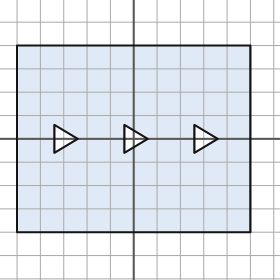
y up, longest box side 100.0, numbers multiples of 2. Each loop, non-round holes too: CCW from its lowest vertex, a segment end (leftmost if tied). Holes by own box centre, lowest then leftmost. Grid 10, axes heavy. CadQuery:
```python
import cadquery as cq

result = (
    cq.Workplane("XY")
    .moveTo(-50.0, -40.0)
    .lineTo(50.0, -40.0)
    .lineTo(50.0, 40.0)
    .lineTo(-50.0, 40.0)
    .close()
    .moveTo(-34.0, -6.0)
    .lineTo(-24.0, 0.0)
    .lineTo(-34.0, 6.0)
    .close()
    .moveTo(-4.0, -6.0)
    .lineTo(6.0, 0.0)
    .lineTo(-4.0, 6.0)
    .close()
    .moveTo(26.0, -6.0)
    .lineTo(36.0, 0.0)
    .lineTo(26.0, 6.0)
    .close()
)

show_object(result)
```